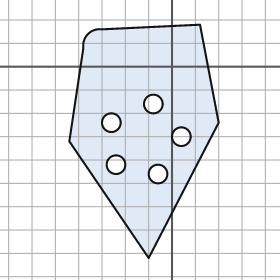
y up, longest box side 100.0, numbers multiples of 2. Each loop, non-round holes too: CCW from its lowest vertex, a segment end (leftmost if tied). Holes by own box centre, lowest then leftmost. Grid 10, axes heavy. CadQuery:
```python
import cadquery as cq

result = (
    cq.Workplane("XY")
    .moveTo(-10.0, -82.0)
    .lineTo(20.0, -24.0)
    .lineTo(12.0, 18.0)
    .lineTo(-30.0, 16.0)
    .threePointArc((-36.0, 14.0), (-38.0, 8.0))
    .lineTo(-44.0, -32.0)
    .close()
    .moveTo(-6.0, -46.0)
    .circle(4.0)
    .moveTo(-24.0, -42.0)
    .circle(4.0)
    .moveTo(4.0, -30.0)
    .circle(4.0)
    .moveTo(-26.0, -24.0)
    .circle(4.0)
    .moveTo(-8.0, -16.0)
    .circle(4.0)
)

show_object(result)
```